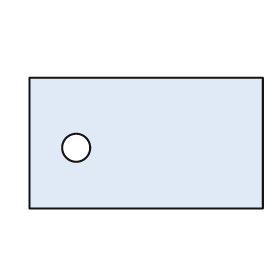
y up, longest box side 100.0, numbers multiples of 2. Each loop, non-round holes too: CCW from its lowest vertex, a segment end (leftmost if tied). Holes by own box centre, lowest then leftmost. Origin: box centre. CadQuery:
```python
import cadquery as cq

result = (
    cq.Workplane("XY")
    .moveTo(-50.0, -28.0)
    .lineTo(50.0, -28.0)
    .lineTo(50.0, 28.0)
    .lineTo(-50.0, 28.0)
    .close()
    .moveTo(-30.0, -2.0)
    .circle(6.0)
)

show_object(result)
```